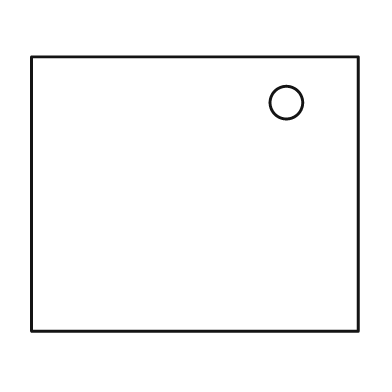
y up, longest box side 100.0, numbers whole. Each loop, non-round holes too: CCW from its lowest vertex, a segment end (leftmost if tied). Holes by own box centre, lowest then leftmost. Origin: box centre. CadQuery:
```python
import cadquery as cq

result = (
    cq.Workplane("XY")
    .moveTo(-50.0, -42.0)
    .lineTo(50.0, -42.0)
    .lineTo(50.0, 42.0)
    .lineTo(-50.0, 42.0)
    .close()
    .moveTo(28.0, 28.0)
    .circle(5.0)
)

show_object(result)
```